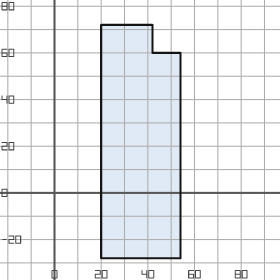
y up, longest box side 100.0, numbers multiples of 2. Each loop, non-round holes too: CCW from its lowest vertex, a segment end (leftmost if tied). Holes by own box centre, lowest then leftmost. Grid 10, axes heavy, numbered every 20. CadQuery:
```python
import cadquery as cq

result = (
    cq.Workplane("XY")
    .moveTo(20.0, -28.0)
    .lineTo(54.0, -28.0)
    .lineTo(54.0, 60.0)
    .lineTo(42.0, 60.0)
    .lineTo(42.0, 72.0)
    .lineTo(20.0, 72.0)
    .close()
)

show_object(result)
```